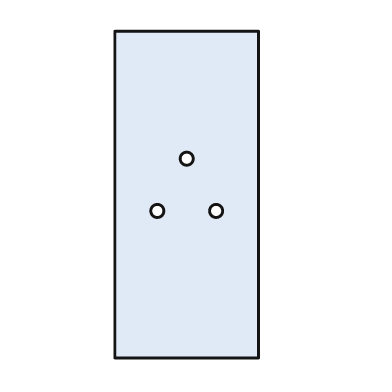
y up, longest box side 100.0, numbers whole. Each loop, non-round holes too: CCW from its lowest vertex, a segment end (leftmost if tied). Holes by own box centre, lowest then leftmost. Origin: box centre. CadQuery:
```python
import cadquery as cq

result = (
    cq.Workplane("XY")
    .moveTo(-22.0, -50.0)
    .lineTo(22.0, -50.0)
    .lineTo(22.0, 50.0)
    .lineTo(-22.0, 50.0)
    .close()
    .moveTo(-9.0, -5.0)
    .circle(2.0)
    .moveTo(9.0, -5.0)
    .circle(2.0)
    .moveTo(0.0, 11.0)
    .circle(2.0)
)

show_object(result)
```